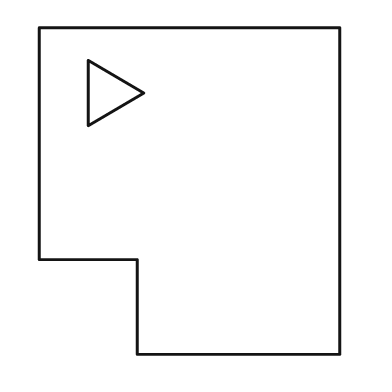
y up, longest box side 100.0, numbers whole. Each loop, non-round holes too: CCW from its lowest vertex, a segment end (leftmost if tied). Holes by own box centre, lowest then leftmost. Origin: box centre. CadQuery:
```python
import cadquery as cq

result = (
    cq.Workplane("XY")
    .moveTo(-16.0, -50.0)
    .lineTo(46.0, -50.0)
    .lineTo(46.0, 50.0)
    .lineTo(-46.0, 50.0)
    .lineTo(-46.0, -21.0)
    .lineTo(-16.0, -21.0)
    .close()
    .moveTo(-31.0, 20.0)
    .lineTo(-14.0, 30.0)
    .lineTo(-31.0, 40.0)
    .close()
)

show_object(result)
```